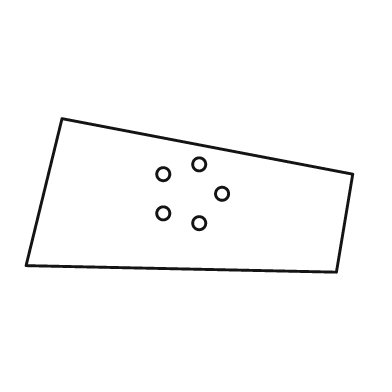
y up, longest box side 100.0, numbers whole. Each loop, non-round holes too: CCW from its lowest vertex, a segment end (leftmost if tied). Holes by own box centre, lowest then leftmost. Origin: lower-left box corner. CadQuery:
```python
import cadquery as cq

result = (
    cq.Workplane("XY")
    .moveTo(95.0, 0.0)
    .lineTo(100.0, 30.0)
    .lineTo(11.0, 47.0)
    .lineTo(0.0, 2.0)
    .close()
    .moveTo(53.0, 15.0)
    .circle(2.0)
    .moveTo(42.0, 18.0)
    .circle(2.0)
    .moveTo(60.0, 24.0)
    .circle(2.0)
    .moveTo(42.0, 30.0)
    .circle(2.0)
    .moveTo(53.0, 33.0)
    .circle(2.0)
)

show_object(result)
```